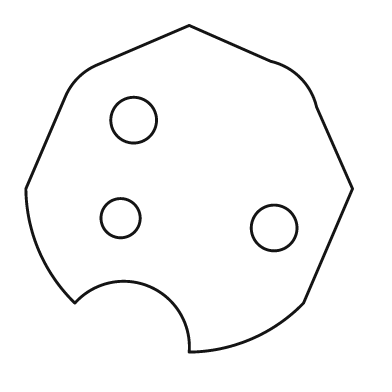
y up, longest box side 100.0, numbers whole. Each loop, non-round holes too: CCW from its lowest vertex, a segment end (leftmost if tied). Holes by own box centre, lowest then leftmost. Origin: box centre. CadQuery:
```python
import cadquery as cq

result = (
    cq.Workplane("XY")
    .moveTo(0.0, -50.0)
    .threePointArc((19.0, -46.0), (35.0, -35.0))
    .lineTo(50.0, 0.0)
    .lineTo(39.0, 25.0)
    .threePointArc((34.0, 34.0), (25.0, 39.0))
    .lineTo(0.0, 50.0)
    .lineTo(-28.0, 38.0)
    .threePointArc((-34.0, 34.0), (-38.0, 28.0))
    .lineTo(-50.0, 0.0)
    .threePointArc((-46.0, -19.0), (-35.0, -35.0))
    .threePointArc((-12.0, -30.0), (0.0, -50.0))
    .close()
    .moveTo(26.0, -12.0)
    .circle(7.0)
    .moveTo(-21.0, -9.0)
    .circle(6.0)
    .moveTo(-17.0, 21.0)
    .circle(7.0)
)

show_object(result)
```